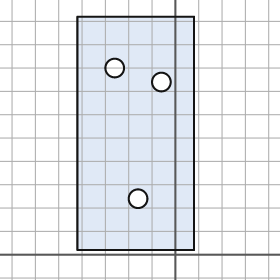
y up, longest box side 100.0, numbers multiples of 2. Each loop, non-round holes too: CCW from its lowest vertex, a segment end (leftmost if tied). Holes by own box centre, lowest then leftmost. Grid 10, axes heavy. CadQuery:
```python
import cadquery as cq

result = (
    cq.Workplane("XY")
    .moveTo(-42.0, 2.0)
    .lineTo(8.0, 2.0)
    .lineTo(8.0, 102.0)
    .lineTo(-42.0, 102.0)
    .close()
    .moveTo(-16.0, 24.0)
    .circle(4.0)
    .moveTo(-6.0, 74.0)
    .circle(4.0)
    .moveTo(-26.0, 80.0)
    .circle(4.0)
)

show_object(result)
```